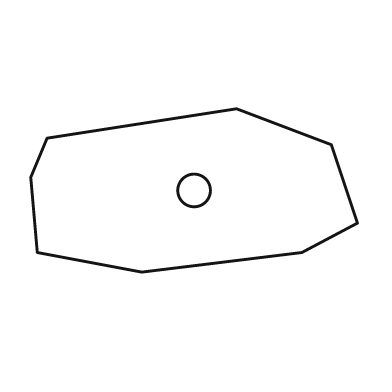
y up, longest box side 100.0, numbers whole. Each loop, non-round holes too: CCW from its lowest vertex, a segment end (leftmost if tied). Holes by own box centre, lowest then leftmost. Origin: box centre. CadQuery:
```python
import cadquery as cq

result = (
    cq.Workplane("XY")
    .moveTo(-16.0, -25.0)
    .lineTo(33.0, -19.0)
    .lineTo(50.0, -10.0)
    .lineTo(42.0, 14.0)
    .lineTo(13.0, 25.0)
    .lineTo(-45.0, 16.0)
    .lineTo(-50.0, 4.0)
    .lineTo(-48.0, -19.0)
    .close()
    .moveTo(0.0, 0.0)
    .circle(5.0)
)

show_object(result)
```